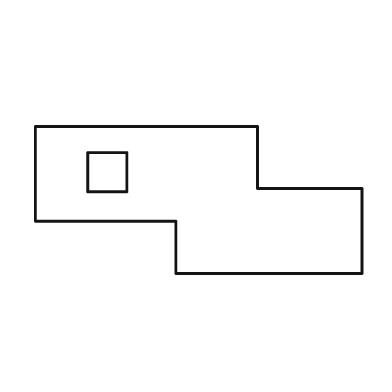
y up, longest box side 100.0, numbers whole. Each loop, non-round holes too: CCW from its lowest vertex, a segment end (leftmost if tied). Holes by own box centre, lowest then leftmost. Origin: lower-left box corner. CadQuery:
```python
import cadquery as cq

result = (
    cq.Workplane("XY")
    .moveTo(43.0, 0.0)
    .lineTo(100.0, 0.0)
    .lineTo(100.0, 26.0)
    .lineTo(68.0, 26.0)
    .lineTo(68.0, 45.0)
    .lineTo(0.0, 45.0)
    .lineTo(0.0, 16.0)
    .lineTo(43.0, 16.0)
    .close()
    .moveTo(16.0, 25.0)
    .lineTo(28.0, 25.0)
    .lineTo(28.0, 37.0)
    .lineTo(16.0, 37.0)
    .close()
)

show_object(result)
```